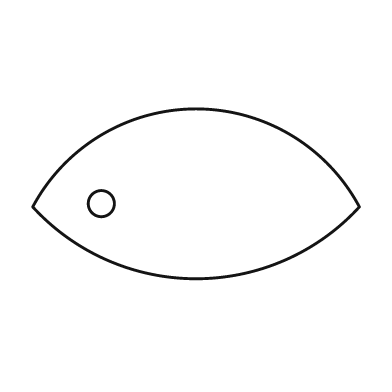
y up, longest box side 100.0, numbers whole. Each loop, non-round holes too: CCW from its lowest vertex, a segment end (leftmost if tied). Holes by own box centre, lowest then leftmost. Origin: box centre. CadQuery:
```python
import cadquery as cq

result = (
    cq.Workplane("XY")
    .moveTo(-50.0, -4.0)
    .threePointArc((0.0, -26.0), (50.0, -4.0))
    .threePointArc((0.0, 26.0), (-50.0, -4.0))
    .close()
    .moveTo(-29.0, -3.0)
    .circle(4.0)
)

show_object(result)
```